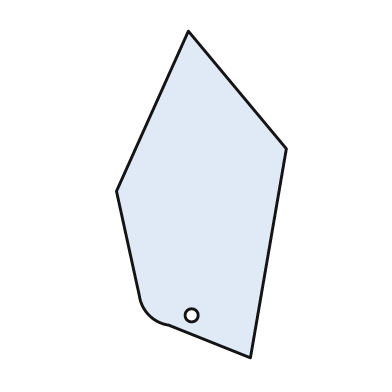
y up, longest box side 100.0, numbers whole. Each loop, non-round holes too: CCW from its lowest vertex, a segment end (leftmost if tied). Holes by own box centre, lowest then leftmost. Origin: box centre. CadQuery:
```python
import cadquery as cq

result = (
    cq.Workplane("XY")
    .moveTo(15.0, -50.0)
    .lineTo(26.0, 14.0)
    .lineTo(-4.0, 50.0)
    .lineTo(-26.0, 1.0)
    .lineTo(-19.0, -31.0)
    .threePointArc((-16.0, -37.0), (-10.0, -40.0))
    .close()
    .moveTo(-3.0, -37.0)
    .circle(2.0)
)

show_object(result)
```